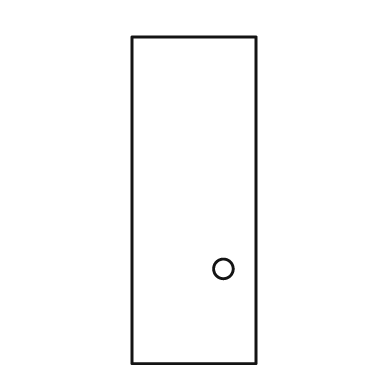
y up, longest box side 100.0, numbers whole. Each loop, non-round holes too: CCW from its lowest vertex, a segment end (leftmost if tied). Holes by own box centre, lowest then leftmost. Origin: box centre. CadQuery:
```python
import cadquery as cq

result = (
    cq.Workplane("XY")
    .moveTo(-19.0, -50.0)
    .lineTo(19.0, -50.0)
    .lineTo(19.0, 50.0)
    .lineTo(-19.0, 50.0)
    .close()
    .moveTo(9.0, -21.0)
    .circle(3.0)
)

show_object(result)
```